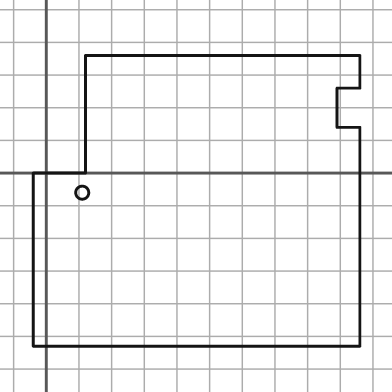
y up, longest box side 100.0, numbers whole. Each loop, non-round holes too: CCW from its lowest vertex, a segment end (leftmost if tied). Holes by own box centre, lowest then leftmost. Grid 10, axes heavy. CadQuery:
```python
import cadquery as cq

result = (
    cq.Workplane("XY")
    .moveTo(-4.0, -53.0)
    .lineTo(96.0, -53.0)
    .lineTo(96.0, 14.0)
    .lineTo(89.0, 14.0)
    .lineTo(89.0, 26.0)
    .lineTo(96.0, 26.0)
    .lineTo(96.0, 36.0)
    .lineTo(12.0, 36.0)
    .lineTo(12.0, 0.0)
    .lineTo(-4.0, 0.0)
    .close()
    .moveTo(11.0, -6.0)
    .circle(2.0)
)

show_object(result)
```